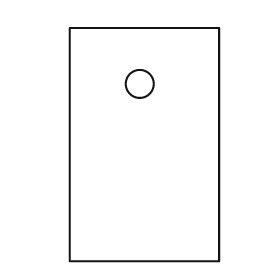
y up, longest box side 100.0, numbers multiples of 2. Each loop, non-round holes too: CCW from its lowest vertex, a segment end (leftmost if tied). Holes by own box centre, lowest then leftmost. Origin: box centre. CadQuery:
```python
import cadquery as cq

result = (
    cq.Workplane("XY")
    .moveTo(-32.0, -50.0)
    .lineTo(32.0, -50.0)
    .lineTo(32.0, 50.0)
    .lineTo(-32.0, 50.0)
    .close()
    .moveTo(-2.0, 26.0)
    .circle(6.0)
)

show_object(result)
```